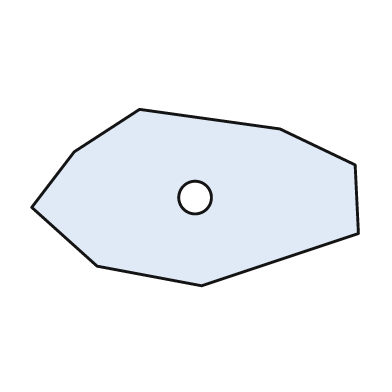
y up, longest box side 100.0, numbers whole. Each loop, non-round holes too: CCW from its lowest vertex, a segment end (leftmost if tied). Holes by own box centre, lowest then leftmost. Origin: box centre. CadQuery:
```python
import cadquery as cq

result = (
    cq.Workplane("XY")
    .moveTo(2.0, -27.0)
    .lineTo(50.0, -11.0)
    .lineTo(49.0, 10.0)
    .lineTo(26.0, 21.0)
    .lineTo(-17.0, 27.0)
    .lineTo(-37.0, 14.0)
    .lineTo(-50.0, -3.0)
    .lineTo(-30.0, -21.0)
    .close()
    .moveTo(0.0, 0.0)
    .circle(5.0)
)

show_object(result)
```